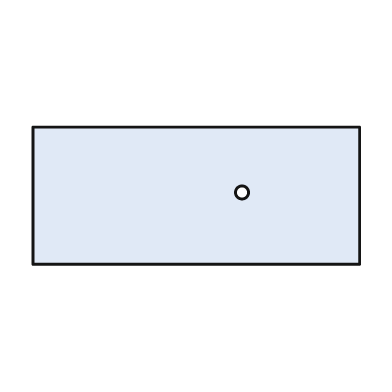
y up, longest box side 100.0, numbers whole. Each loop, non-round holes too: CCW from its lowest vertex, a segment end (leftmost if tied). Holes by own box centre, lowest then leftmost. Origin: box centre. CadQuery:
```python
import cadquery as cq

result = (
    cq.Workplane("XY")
    .moveTo(-50.0, -21.0)
    .lineTo(50.0, -21.0)
    .lineTo(50.0, 21.0)
    .lineTo(-50.0, 21.0)
    .close()
    .moveTo(14.0, 1.0)
    .circle(2.0)
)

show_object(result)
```